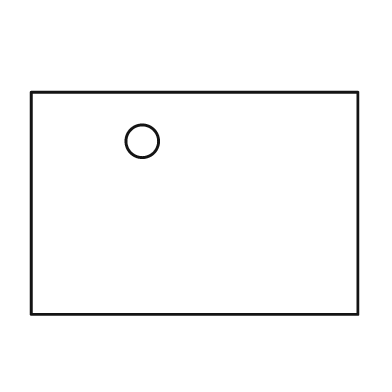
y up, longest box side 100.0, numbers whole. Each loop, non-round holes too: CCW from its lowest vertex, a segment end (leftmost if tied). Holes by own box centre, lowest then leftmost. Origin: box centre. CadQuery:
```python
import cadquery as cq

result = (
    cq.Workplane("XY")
    .moveTo(-50.0, -34.0)
    .lineTo(50.0, -34.0)
    .lineTo(50.0, 34.0)
    .lineTo(-50.0, 34.0)
    .close()
    .moveTo(-16.0, 19.0)
    .circle(5.0)
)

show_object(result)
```